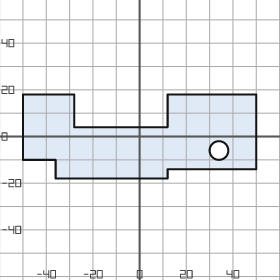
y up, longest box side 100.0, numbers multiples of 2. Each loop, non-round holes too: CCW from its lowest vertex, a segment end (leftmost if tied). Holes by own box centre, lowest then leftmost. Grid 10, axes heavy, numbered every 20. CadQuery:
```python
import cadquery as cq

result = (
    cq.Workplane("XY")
    .moveTo(-36.0, -18.0)
    .lineTo(12.0, -18.0)
    .lineTo(12.0, -14.0)
    .lineTo(50.0, -14.0)
    .lineTo(50.0, 18.0)
    .lineTo(12.0, 18.0)
    .lineTo(12.0, 4.0)
    .lineTo(-28.0, 4.0)
    .lineTo(-28.0, 18.0)
    .lineTo(-50.0, 18.0)
    .lineTo(-50.0, -10.0)
    .lineTo(-36.0, -10.0)
    .close()
    .moveTo(34.0, -6.0)
    .circle(4.0)
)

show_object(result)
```